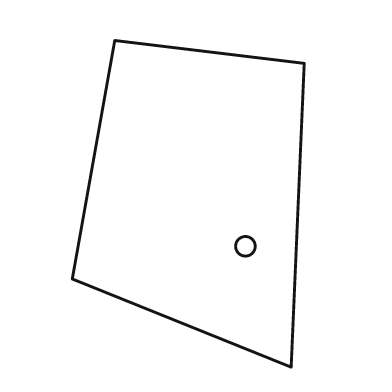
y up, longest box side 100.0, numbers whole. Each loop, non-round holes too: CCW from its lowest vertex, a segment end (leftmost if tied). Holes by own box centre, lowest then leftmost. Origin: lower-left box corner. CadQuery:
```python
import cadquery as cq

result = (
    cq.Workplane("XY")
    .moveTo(67.0, 0.0)
    .lineTo(71.0, 93.0)
    .lineTo(13.0, 100.0)
    .lineTo(0.0, 27.0)
    .close()
    .moveTo(53.0, 37.0)
    .circle(3.0)
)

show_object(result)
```